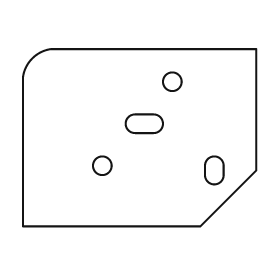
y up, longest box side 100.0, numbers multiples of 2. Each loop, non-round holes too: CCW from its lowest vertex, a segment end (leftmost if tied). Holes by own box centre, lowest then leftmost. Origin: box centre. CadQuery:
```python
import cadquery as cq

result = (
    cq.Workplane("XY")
    .moveTo(-50.0, -38.0)
    .lineTo(26.0, -38.0)
    .lineTo(50.0, -14.0)
    .lineTo(50.0, 38.0)
    .lineTo(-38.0, 38.0)
    .threePointArc((-46.0, 34.0), (-50.0, 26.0))
    .close()
    .moveTo(28.0, -16.0)
    .threePointArc((32.0, -20.0), (36.0, -16.0))
    .lineTo(36.0, -12.0)
    .threePointArc((32.0, -8.0), (28.0, -12.0))
    .close()
    .moveTo(-16.0, -12.0)
    .circle(4.0)
    .moveTo(-2.0, 2.0)
    .lineTo(6.0, 2.0)
    .threePointArc((10.0, 6.0), (6.0, 10.0))
    .lineTo(-2.0, 10.0)
    .threePointArc((-6.0, 6.0), (-2.0, 2.0))
    .close()
    .moveTo(14.0, 24.0)
    .circle(4.0)
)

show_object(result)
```